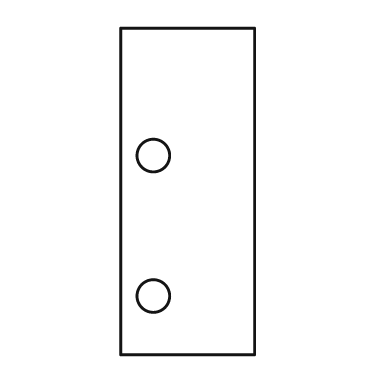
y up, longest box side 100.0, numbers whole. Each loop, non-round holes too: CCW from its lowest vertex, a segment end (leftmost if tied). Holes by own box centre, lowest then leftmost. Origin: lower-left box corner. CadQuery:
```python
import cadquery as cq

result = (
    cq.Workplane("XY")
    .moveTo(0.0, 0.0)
    .lineTo(41.0, 0.0)
    .lineTo(41.0, 100.0)
    .lineTo(0.0, 100.0)
    .close()
    .moveTo(10.0, 18.0)
    .circle(5.0)
    .moveTo(10.0, 61.0)
    .circle(5.0)
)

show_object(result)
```